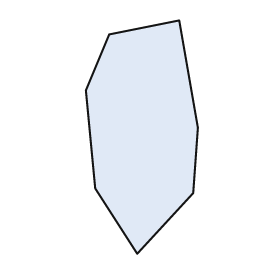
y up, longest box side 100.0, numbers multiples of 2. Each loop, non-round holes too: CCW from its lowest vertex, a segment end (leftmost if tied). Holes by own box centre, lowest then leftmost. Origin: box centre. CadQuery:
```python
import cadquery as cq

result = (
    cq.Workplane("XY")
    .moveTo(-2.0, -50.0)
    .lineTo(22.0, -24.0)
    .lineTo(24.0, 4.0)
    .lineTo(16.0, 50.0)
    .lineTo(-14.0, 44.0)
    .lineTo(-24.0, 20.0)
    .lineTo(-20.0, -22.0)
    .close()
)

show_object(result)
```